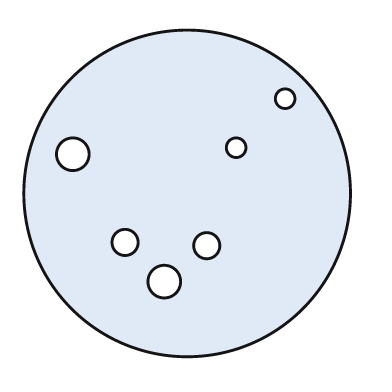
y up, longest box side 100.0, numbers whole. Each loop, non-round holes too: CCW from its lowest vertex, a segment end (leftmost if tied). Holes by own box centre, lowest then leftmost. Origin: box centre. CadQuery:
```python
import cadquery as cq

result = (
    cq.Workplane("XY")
    .moveTo(0.0, 0.0)
    .circle(50.0)
    .moveTo(-7.0, -27.0)
    .circle(5.0)
    .moveTo(6.0, -16.0)
    .circle(4.0)
    .moveTo(-19.0, -15.0)
    .circle(4.0)
    .moveTo(-35.0, 12.0)
    .circle(5.0)
    .moveTo(15.0, 14.0)
    .circle(3.0)
    .moveTo(30.0, 29.0)
    .circle(3.0)
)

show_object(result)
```